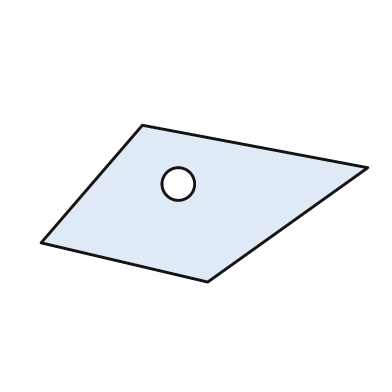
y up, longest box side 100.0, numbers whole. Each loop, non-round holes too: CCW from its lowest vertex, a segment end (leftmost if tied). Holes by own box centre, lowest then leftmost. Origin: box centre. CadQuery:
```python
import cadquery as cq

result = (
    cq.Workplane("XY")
    .moveTo(1.0, -24.0)
    .lineTo(50.0, 11.0)
    .lineTo(-19.0, 24.0)
    .lineTo(-50.0, -12.0)
    .close()
    .moveTo(-8.0, 6.0)
    .circle(5.0)
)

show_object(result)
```